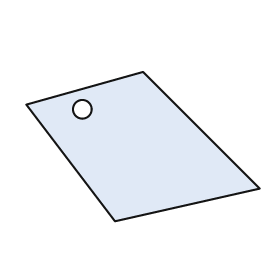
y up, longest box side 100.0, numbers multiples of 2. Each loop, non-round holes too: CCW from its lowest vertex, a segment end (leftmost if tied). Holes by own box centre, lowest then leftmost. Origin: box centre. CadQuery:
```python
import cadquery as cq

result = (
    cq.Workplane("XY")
    .moveTo(-12.0, -32.0)
    .lineTo(50.0, -18.0)
    .lineTo(0.0, 32.0)
    .lineTo(-50.0, 18.0)
    .close()
    .moveTo(-26.0, 16.0)
    .circle(4.0)
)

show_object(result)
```